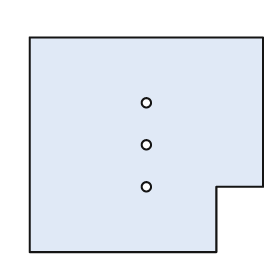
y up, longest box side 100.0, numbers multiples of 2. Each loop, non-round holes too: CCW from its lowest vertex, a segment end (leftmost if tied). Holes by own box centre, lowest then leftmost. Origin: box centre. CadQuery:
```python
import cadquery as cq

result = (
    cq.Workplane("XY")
    .moveTo(-50.0, -46.0)
    .lineTo(30.0, -46.0)
    .lineTo(30.0, -18.0)
    .lineTo(50.0, -18.0)
    .lineTo(50.0, 46.0)
    .lineTo(-50.0, 46.0)
    .close()
    .moveTo(0.0, -18.0)
    .circle(2.0)
    .moveTo(0.0, 0.0)
    .circle(2.0)
    .moveTo(0.0, 18.0)
    .circle(2.0)
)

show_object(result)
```